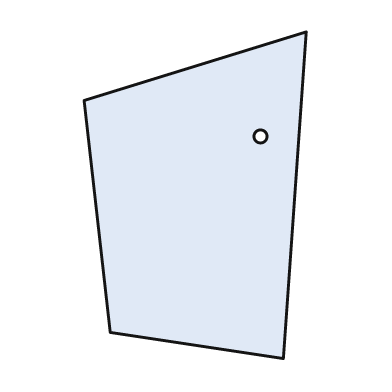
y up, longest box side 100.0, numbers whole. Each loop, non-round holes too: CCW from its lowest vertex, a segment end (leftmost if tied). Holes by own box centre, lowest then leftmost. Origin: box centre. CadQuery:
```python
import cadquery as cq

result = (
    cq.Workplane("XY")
    .moveTo(27.0, -50.0)
    .lineTo(34.0, 50.0)
    .lineTo(-34.0, 29.0)
    .lineTo(-26.0, -42.0)
    .close()
    .moveTo(20.0, 18.0)
    .circle(2.0)
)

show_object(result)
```